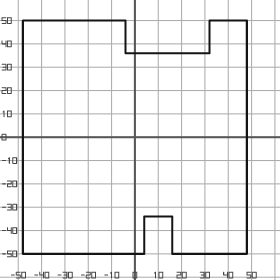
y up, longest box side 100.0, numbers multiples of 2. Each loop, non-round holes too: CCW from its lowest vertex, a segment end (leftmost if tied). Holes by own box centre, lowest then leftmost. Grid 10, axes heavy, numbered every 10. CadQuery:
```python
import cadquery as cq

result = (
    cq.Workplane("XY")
    .moveTo(-48.0, -50.0)
    .lineTo(4.0, -50.0)
    .lineTo(4.0, -34.0)
    .lineTo(16.0, -34.0)
    .lineTo(16.0, -50.0)
    .lineTo(48.0, -50.0)
    .lineTo(48.0, 50.0)
    .lineTo(32.0, 50.0)
    .lineTo(32.0, 36.0)
    .lineTo(-4.0, 36.0)
    .lineTo(-4.0, 50.0)
    .lineTo(-48.0, 50.0)
    .close()
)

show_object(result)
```